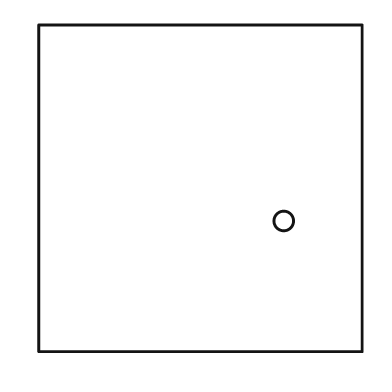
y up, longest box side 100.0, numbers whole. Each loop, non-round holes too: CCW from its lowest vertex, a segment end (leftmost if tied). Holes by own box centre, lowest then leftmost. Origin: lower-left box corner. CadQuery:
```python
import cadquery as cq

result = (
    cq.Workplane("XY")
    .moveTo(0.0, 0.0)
    .lineTo(99.0, 0.0)
    .lineTo(99.0, 100.0)
    .lineTo(0.0, 100.0)
    .close()
    .moveTo(75.0, 40.0)
    .circle(3.0)
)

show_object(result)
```